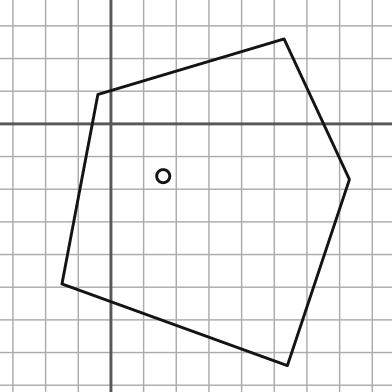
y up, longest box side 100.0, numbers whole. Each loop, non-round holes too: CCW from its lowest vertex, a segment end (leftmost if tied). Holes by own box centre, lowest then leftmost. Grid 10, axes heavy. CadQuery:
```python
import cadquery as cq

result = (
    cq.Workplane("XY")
    .moveTo(54.0, -74.0)
    .lineTo(73.0, -17.0)
    .lineTo(53.0, 26.0)
    .lineTo(-4.0, 9.0)
    .lineTo(-15.0, -49.0)
    .close()
    .moveTo(16.0, -16.0)
    .circle(2.0)
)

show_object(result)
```